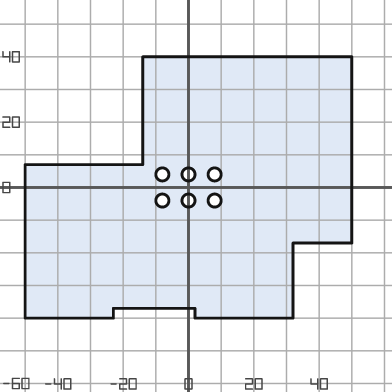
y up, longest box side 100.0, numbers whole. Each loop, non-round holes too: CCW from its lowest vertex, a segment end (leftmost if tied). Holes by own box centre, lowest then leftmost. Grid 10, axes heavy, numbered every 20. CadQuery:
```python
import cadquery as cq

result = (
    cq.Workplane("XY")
    .moveTo(-50.0, -40.0)
    .lineTo(-23.0, -40.0)
    .lineTo(-23.0, -37.0)
    .lineTo(2.0, -37.0)
    .lineTo(2.0, -40.0)
    .lineTo(32.0, -40.0)
    .lineTo(32.0, -17.0)
    .lineTo(50.0, -17.0)
    .lineTo(50.0, 40.0)
    .lineTo(-14.0, 40.0)
    .lineTo(-14.0, 7.0)
    .lineTo(-50.0, 7.0)
    .close()
    .moveTo(-8.0, -4.0)
    .circle(2.0)
    .moveTo(0.0, -4.0)
    .circle(2.0)
    .moveTo(8.0, -4.0)
    .circle(2.0)
    .moveTo(-8.0, 4.0)
    .circle(2.0)
    .moveTo(0.0, 4.0)
    .circle(2.0)
    .moveTo(8.0, 4.0)
    .circle(2.0)
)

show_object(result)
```